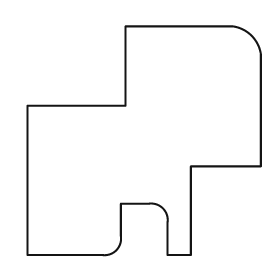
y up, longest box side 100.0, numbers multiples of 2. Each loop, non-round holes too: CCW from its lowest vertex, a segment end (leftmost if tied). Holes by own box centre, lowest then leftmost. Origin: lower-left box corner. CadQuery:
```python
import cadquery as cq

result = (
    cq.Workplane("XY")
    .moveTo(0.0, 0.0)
    .lineTo(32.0, 0.0)
    .threePointArc((38.0, 2.0), (40.0, 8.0))
    .lineTo(40.0, 22.0)
    .lineTo(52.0, 22.0)
    .threePointArc((58.0, 20.0), (60.0, 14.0))
    .lineTo(60.0, 0.0)
    .lineTo(70.0, 0.0)
    .lineTo(70.0, 38.0)
    .lineTo(100.0, 38.0)
    .lineTo(100.0, 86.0)
    .threePointArc((96.0, 94.0), (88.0, 98.0))
    .lineTo(42.0, 98.0)
    .lineTo(42.0, 64.0)
    .lineTo(0.0, 64.0)
    .close()
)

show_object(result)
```